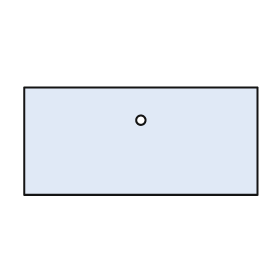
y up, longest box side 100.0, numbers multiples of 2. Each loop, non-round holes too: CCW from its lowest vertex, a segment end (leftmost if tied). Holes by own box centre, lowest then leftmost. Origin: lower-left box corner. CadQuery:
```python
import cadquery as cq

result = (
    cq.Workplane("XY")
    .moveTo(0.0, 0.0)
    .lineTo(100.0, 0.0)
    .lineTo(100.0, 46.0)
    .lineTo(0.0, 46.0)
    .close()
    .moveTo(50.0, 32.0)
    .circle(2.0)
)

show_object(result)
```